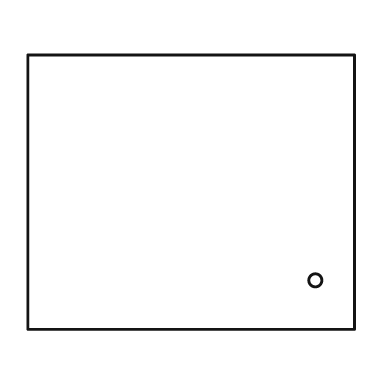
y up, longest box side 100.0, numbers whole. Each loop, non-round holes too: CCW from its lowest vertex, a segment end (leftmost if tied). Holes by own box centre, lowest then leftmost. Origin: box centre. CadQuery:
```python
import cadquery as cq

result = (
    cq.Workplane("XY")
    .moveTo(-50.0, -42.0)
    .lineTo(50.0, -42.0)
    .lineTo(50.0, 42.0)
    .lineTo(-50.0, 42.0)
    .close()
    .moveTo(38.0, -27.0)
    .circle(2.0)
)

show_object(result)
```